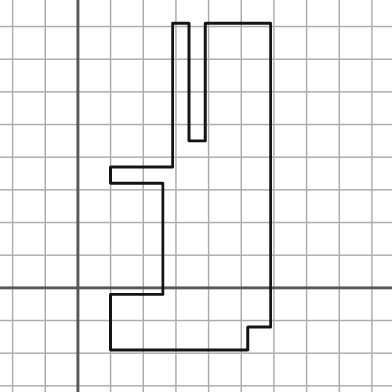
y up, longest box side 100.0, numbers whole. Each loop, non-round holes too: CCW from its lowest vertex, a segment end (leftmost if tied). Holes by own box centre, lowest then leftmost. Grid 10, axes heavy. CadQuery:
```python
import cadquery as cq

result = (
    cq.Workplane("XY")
    .moveTo(10.0, -19.0)
    .lineTo(52.0, -19.0)
    .lineTo(52.0, -12.0)
    .lineTo(59.0, -12.0)
    .lineTo(59.0, 81.0)
    .lineTo(39.0, 81.0)
    .lineTo(39.0, 45.0)
    .lineTo(34.0, 45.0)
    .lineTo(34.0, 81.0)
    .lineTo(29.0, 81.0)
    .lineTo(29.0, 37.0)
    .lineTo(10.0, 37.0)
    .lineTo(10.0, 32.0)
    .lineTo(26.0, 32.0)
    .lineTo(26.0, -2.0)
    .lineTo(10.0, -2.0)
    .close()
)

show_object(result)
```